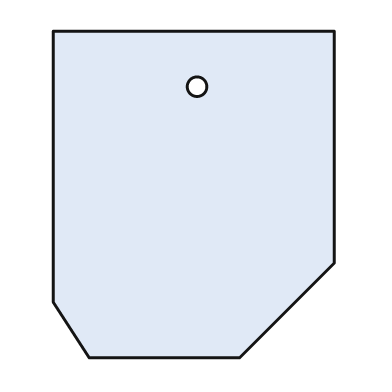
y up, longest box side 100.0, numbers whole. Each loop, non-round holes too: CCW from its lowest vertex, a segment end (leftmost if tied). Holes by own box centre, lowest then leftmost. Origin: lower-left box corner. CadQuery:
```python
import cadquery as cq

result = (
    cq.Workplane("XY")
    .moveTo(11.0, 0.0)
    .lineTo(57.0, 0.0)
    .lineTo(86.0, 29.0)
    .lineTo(86.0, 100.0)
    .lineTo(0.0, 100.0)
    .lineTo(0.0, 17.0)
    .close()
    .moveTo(44.0, 83.0)
    .circle(3.0)
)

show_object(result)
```